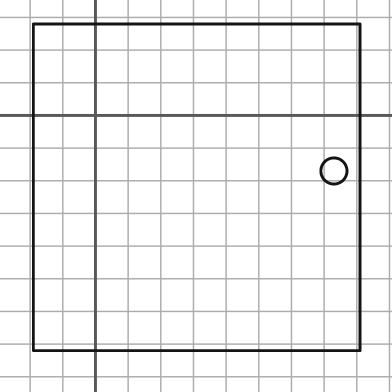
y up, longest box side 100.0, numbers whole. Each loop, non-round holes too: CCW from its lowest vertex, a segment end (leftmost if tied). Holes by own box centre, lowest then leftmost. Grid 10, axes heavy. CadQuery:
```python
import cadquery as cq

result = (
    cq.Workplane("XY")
    .moveTo(-19.0, -72.0)
    .lineTo(81.0, -72.0)
    .lineTo(81.0, 28.0)
    .lineTo(-19.0, 28.0)
    .close()
    .moveTo(73.0, -17.0)
    .circle(4.0)
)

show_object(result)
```